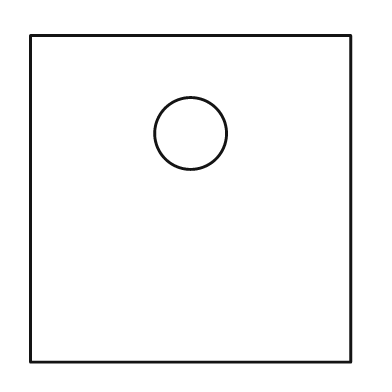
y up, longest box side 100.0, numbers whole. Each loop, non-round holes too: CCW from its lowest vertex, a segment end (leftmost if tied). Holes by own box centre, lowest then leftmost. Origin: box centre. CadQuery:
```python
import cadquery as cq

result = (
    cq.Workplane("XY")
    .moveTo(-49.0, -50.0)
    .lineTo(49.0, -50.0)
    .lineTo(49.0, 50.0)
    .lineTo(-49.0, 50.0)
    .close()
    .moveTo(0.0, 20.0)
    .circle(11.0)
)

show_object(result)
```